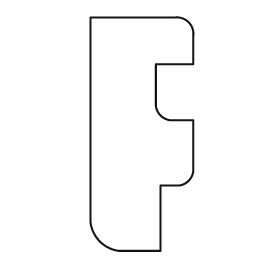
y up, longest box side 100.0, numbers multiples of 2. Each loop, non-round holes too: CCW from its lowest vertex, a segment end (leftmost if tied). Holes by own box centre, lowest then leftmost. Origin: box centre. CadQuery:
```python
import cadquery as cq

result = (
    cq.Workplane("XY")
    .moveTo(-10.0, -50.0)
    .lineTo(8.0, -50.0)
    .lineTo(8.0, -22.0)
    .lineTo(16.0, -22.0)
    .threePointArc((20.0, -20.0), (22.0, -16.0))
    .lineTo(22.0, 6.0)
    .lineTo(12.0, 6.0)
    .threePointArc((8.0, 8.0), (6.0, 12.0))
    .lineTo(6.0, 30.0)
    .lineTo(22.0, 30.0)
    .lineTo(22.0, 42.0)
    .threePointArc((20.0, 48.0), (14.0, 50.0))
    .lineTo(-22.0, 50.0)
    .lineTo(-22.0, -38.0)
    .threePointArc((-18.0, -46.0), (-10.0, -50.0))
    .close()
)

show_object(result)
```